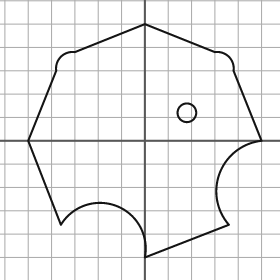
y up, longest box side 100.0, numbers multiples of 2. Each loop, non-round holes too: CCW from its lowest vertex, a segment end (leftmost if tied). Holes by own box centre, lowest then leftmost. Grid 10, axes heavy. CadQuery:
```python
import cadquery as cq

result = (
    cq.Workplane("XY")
    .moveTo(0.0, -50.0)
    .lineTo(36.0, -36.0)
    .threePointArc((32.0, -14.0), (50.0, 0.0))
    .lineTo(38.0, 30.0)
    .threePointArc((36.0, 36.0), (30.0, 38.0))
    .lineTo(0.0, 50.0)
    .lineTo(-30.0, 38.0)
    .threePointArc((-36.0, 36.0), (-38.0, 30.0))
    .lineTo(-50.0, 0.0)
    .lineTo(-36.0, -36.0)
    .threePointArc((-12.0, -28.0), (0.0, -50.0))
    .close()
    .moveTo(18.0, 12.0)
    .circle(4.0)
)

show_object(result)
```